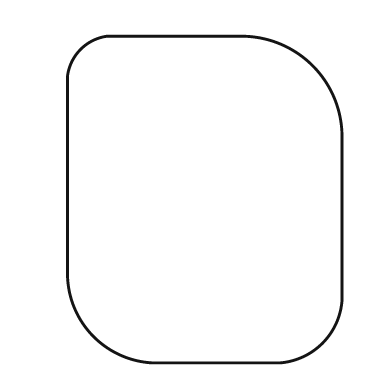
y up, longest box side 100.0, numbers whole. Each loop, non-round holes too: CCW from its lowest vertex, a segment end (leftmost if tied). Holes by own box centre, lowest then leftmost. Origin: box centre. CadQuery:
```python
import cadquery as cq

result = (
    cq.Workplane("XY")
    .moveTo(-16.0, -50.0)
    .lineTo(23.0, -50.0)
    .threePointArc((36.0, -44.0), (42.0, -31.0))
    .lineTo(42.0, 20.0)
    .threePointArc((33.0, 41.0), (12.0, 50.0))
    .lineTo(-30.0, 50.0)
    .threePointArc((-38.0, 46.0), (-42.0, 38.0))
    .lineTo(-42.0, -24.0)
    .threePointArc((-34.0, -42.0), (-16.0, -50.0))
    .close()
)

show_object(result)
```